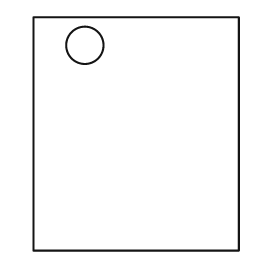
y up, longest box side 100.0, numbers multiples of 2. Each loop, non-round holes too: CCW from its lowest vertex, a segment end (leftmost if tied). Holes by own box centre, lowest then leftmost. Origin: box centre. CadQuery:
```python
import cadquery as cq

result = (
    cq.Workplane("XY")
    .moveTo(-44.0, -50.0)
    .lineTo(44.0, -50.0)
    .lineTo(44.0, 50.0)
    .lineTo(-44.0, 50.0)
    .close()
    .moveTo(-22.0, 38.0)
    .circle(8.0)
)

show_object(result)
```